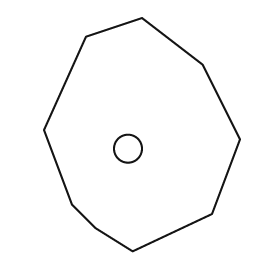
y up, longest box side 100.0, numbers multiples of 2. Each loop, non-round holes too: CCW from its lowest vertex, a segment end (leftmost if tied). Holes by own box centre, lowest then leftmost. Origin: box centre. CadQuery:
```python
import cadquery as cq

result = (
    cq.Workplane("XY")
    .moveTo(-4.0, -50.0)
    .lineTo(30.0, -34.0)
    .lineTo(42.0, -2.0)
    .lineTo(26.0, 30.0)
    .lineTo(0.0, 50.0)
    .lineTo(-24.0, 42.0)
    .lineTo(-42.0, 2.0)
    .lineTo(-30.0, -30.0)
    .lineTo(-20.0, -40.0)
    .close()
    .moveTo(-6.0, -6.0)
    .circle(6.0)
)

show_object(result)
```